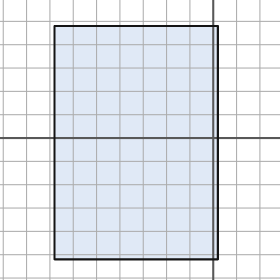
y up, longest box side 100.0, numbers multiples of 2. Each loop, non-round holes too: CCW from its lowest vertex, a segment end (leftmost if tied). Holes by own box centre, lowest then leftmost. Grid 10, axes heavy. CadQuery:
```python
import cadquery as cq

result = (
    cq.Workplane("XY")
    .moveTo(-68.0, -52.0)
    .lineTo(2.0, -52.0)
    .lineTo(2.0, 48.0)
    .lineTo(-68.0, 48.0)
    .close()
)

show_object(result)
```